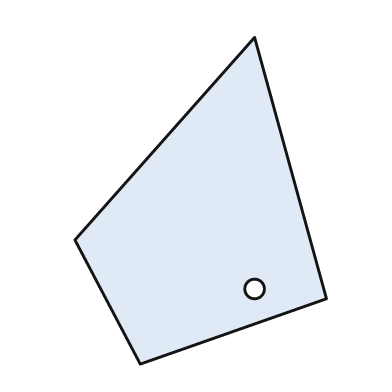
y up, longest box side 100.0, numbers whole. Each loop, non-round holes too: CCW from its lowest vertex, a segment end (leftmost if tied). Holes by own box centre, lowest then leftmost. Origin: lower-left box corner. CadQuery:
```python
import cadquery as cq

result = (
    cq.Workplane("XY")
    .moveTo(20.0, 0.0)
    .lineTo(77.0, 20.0)
    .lineTo(55.0, 100.0)
    .lineTo(0.0, 38.0)
    .close()
    .moveTo(55.0, 23.0)
    .circle(3.0)
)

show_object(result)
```